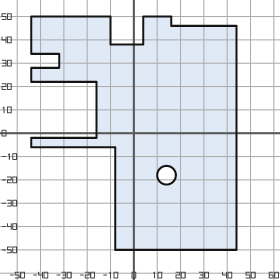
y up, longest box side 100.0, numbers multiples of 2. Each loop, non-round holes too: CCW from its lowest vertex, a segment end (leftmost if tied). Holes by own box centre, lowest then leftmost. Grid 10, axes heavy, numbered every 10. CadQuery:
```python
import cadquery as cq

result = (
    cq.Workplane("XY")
    .moveTo(-8.0, -50.0)
    .lineTo(44.0, -50.0)
    .lineTo(44.0, 46.0)
    .lineTo(16.0, 46.0)
    .lineTo(16.0, 50.0)
    .lineTo(4.0, 50.0)
    .lineTo(4.0, 38.0)
    .lineTo(-10.0, 38.0)
    .lineTo(-10.0, 50.0)
    .lineTo(-44.0, 50.0)
    .lineTo(-44.0, 34.0)
    .lineTo(-32.0, 34.0)
    .lineTo(-32.0, 28.0)
    .lineTo(-44.0, 28.0)
    .lineTo(-44.0, 22.0)
    .lineTo(-16.0, 22.0)
    .lineTo(-16.0, -2.0)
    .lineTo(-44.0, -2.0)
    .lineTo(-44.0, -6.0)
    .lineTo(-8.0, -6.0)
    .close()
    .moveTo(14.0, -18.0)
    .circle(4.0)
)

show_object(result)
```